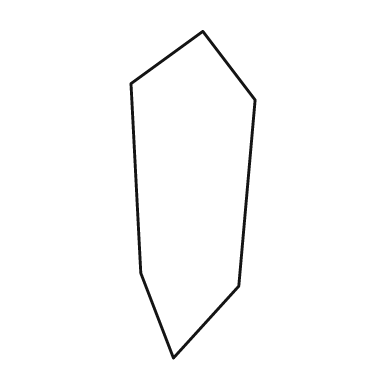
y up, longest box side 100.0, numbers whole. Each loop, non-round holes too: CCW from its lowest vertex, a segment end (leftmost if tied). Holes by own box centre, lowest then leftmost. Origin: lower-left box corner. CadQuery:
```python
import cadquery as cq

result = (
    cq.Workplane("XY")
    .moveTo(13.0, 0.0)
    .lineTo(33.0, 22.0)
    .lineTo(38.0, 79.0)
    .lineTo(22.0, 100.0)
    .lineTo(0.0, 84.0)
    .lineTo(3.0, 26.0)
    .close()
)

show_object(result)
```